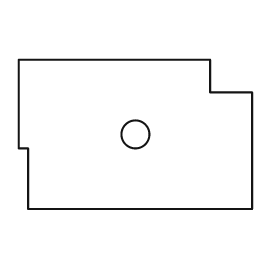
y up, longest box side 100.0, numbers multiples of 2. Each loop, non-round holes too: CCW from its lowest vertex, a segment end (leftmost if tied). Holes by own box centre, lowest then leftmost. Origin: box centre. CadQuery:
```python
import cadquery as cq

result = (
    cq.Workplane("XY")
    .moveTo(-46.0, -32.0)
    .lineTo(50.0, -32.0)
    .lineTo(50.0, 18.0)
    .lineTo(32.0, 18.0)
    .lineTo(32.0, 32.0)
    .lineTo(-50.0, 32.0)
    .lineTo(-50.0, -6.0)
    .lineTo(-46.0, -6.0)
    .close()
    .moveTo(0.0, 0.0)
    .circle(6.0)
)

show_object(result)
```